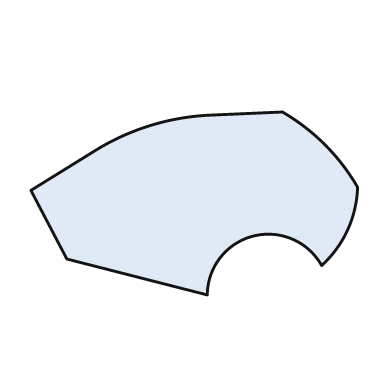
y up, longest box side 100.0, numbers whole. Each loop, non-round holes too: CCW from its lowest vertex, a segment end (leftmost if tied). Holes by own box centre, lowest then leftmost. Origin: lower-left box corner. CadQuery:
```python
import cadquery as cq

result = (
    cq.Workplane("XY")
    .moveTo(54.0, 0.0)
    .threePointArc((68.0, 18.0), (89.0, 9.0))
    .threePointArc((97.0, 20.0), (100.0, 33.0))
    .threePointArc((90.0, 46.0), (77.0, 56.0))
    .lineTo(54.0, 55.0)
    .threePointArc((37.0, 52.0), (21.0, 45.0))
    .lineTo(0.0, 32.0)
    .lineTo(11.0, 11.0)
    .close()
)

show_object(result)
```